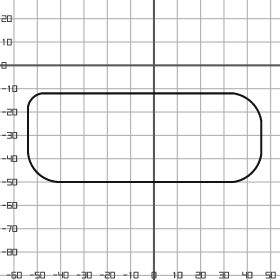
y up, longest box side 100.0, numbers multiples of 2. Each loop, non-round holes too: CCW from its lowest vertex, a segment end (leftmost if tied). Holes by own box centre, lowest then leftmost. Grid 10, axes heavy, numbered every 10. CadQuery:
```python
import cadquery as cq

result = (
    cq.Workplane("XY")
    .moveTo(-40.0, -50.0)
    .lineTo(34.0, -50.0)
    .threePointArc((42.0, -46.0), (46.0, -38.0))
    .lineTo(46.0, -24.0)
    .threePointArc((42.0, -16.0), (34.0, -12.0))
    .lineTo(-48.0, -12.0)
    .threePointArc((-52.0, -14.0), (-54.0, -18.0))
    .lineTo(-54.0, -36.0)
    .threePointArc((-50.0, -46.0), (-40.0, -50.0))
    .close()
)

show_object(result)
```